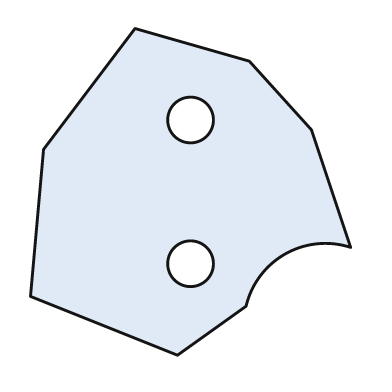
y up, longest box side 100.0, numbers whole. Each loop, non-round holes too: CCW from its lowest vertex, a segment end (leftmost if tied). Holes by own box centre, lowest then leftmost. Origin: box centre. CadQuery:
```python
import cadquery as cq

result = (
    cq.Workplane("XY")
    .moveTo(-4.0, -50.0)
    .lineTo(17.0, -35.0)
    .threePointArc((29.0, -19.0), (49.0, -17.0))
    .lineTo(37.0, 19.0)
    .lineTo(18.0, 40.0)
    .lineTo(-17.0, 50.0)
    .lineTo(-45.0, 13.0)
    .lineTo(-49.0, -32.0)
    .close()
    .moveTo(0.0, -22.0)
    .circle(7.0)
    .moveTo(0.0, 22.0)
    .circle(7.0)
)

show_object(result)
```